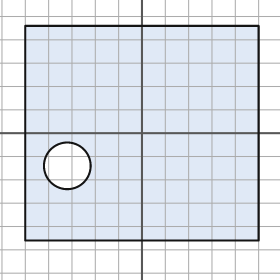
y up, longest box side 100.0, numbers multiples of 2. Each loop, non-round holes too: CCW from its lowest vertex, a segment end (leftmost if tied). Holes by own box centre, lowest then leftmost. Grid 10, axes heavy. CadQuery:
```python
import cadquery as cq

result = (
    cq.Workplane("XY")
    .moveTo(-50.0, -46.0)
    .lineTo(50.0, -46.0)
    .lineTo(50.0, 46.0)
    .lineTo(-50.0, 46.0)
    .close()
    .moveTo(-32.0, -14.0)
    .circle(10.0)
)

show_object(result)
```